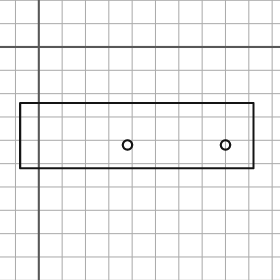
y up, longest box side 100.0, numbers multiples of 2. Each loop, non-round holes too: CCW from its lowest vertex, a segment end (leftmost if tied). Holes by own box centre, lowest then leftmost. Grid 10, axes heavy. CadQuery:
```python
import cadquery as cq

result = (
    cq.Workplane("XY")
    .moveTo(-8.0, -52.0)
    .lineTo(92.0, -52.0)
    .lineTo(92.0, -24.0)
    .lineTo(-8.0, -24.0)
    .close()
    .moveTo(38.0, -42.0)
    .circle(2.0)
    .moveTo(80.0, -42.0)
    .circle(2.0)
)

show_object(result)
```